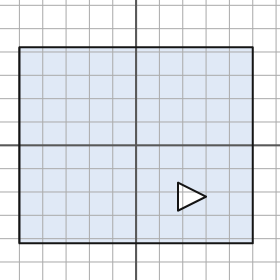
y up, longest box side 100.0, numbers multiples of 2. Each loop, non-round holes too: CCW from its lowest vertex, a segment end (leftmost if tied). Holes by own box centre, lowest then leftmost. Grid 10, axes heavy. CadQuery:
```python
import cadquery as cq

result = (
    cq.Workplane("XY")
    .moveTo(-50.0, -42.0)
    .lineTo(50.0, -42.0)
    .lineTo(50.0, 42.0)
    .lineTo(-50.0, 42.0)
    .close()
    .moveTo(18.0, -28.0)
    .lineTo(30.0, -22.0)
    .lineTo(18.0, -16.0)
    .close()
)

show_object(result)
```